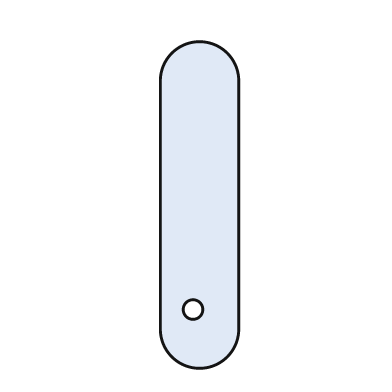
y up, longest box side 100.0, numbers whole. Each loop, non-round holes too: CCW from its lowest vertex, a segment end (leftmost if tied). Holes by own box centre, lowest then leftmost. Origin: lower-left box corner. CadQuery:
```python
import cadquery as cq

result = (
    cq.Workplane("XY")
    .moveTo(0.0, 12.0)
    .threePointArc((12.0, 0.0), (24.0, 12.0))
    .lineTo(24.0, 88.0)
    .threePointArc((12.0, 100.0), (0.0, 88.0))
    .close()
    .moveTo(10.0, 18.0)
    .circle(3.0)
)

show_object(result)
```